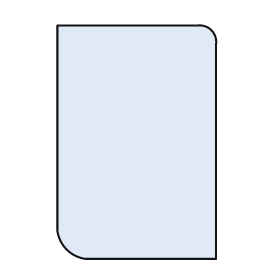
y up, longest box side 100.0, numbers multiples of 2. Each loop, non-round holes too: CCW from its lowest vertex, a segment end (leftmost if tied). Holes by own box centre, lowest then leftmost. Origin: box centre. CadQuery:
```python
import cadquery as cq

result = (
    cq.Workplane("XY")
    .moveTo(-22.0, -50.0)
    .lineTo(34.0, -50.0)
    .lineTo(34.0, 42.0)
    .threePointArc((32.0, 48.0), (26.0, 50.0))
    .lineTo(-34.0, 50.0)
    .lineTo(-34.0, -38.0)
    .threePointArc((-30.0, -46.0), (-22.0, -50.0))
    .close()
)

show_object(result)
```